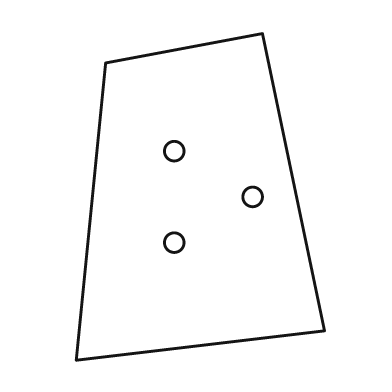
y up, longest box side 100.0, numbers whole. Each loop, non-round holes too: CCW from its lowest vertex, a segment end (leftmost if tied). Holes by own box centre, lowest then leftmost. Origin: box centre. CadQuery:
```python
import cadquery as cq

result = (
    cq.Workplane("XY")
    .moveTo(-38.0, -50.0)
    .lineTo(38.0, -41.0)
    .lineTo(19.0, 50.0)
    .lineTo(-29.0, 41.0)
    .close()
    .moveTo(-8.0, -14.0)
    .circle(3.0)
    .moveTo(16.0, 0.0)
    .circle(3.0)
    .moveTo(-8.0, 14.0)
    .circle(3.0)
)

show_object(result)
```